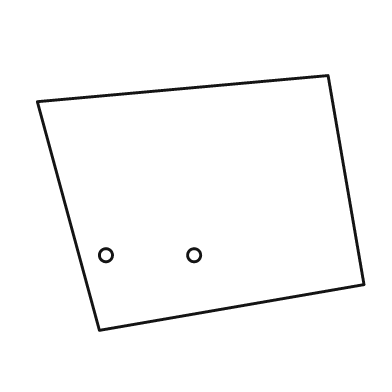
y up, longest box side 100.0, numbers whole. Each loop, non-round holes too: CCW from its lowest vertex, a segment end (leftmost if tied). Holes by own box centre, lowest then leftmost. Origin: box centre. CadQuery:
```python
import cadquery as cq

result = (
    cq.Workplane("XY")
    .moveTo(-31.0, -39.0)
    .lineTo(50.0, -25.0)
    .lineTo(39.0, 39.0)
    .lineTo(-50.0, 31.0)
    .close()
    .moveTo(-29.0, -16.0)
    .circle(2.0)
    .moveTo(-2.0, -16.0)
    .circle(2.0)
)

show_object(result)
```